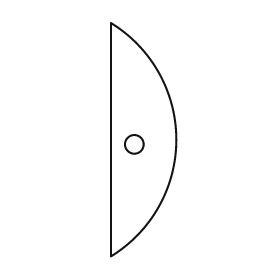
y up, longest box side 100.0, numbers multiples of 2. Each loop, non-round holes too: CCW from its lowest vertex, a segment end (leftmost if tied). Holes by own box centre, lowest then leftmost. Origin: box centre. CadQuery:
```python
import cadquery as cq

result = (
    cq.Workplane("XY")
    .moveTo(-14.0, -50.0)
    .threePointArc((14.0, 0.0), (-14.0, 50.0))
    .close()
    .moveTo(-4.0, -2.0)
    .circle(4.0)
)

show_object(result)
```